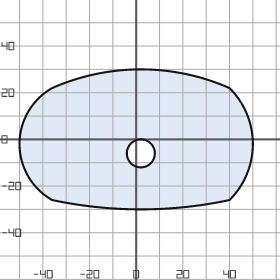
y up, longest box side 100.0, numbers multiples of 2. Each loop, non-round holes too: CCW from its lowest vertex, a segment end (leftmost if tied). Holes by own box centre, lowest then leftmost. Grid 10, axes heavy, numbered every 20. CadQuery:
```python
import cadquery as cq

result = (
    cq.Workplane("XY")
    .moveTo(-36.0, -26.0)
    .threePointArc((2.0, -30.0), (40.0, -26.0))
    .threePointArc((50.0, -2.0), (40.0, 22.0))
    .threePointArc((2.0, 30.0), (-36.0, 22.0))
    .threePointArc((-50.0, -2.0), (-36.0, -26.0))
    .close()
    .moveTo(2.0, -6.0)
    .circle(6.0)
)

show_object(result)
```